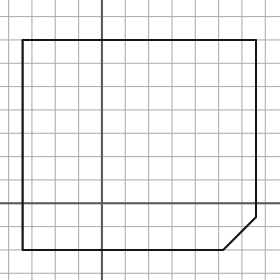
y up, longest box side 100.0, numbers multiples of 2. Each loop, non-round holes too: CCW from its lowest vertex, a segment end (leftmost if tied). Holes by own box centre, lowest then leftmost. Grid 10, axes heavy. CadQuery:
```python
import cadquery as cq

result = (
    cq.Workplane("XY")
    .moveTo(-34.0, -20.0)
    .lineTo(52.0, -20.0)
    .lineTo(66.0, -6.0)
    .lineTo(66.0, 70.0)
    .lineTo(-34.0, 70.0)
    .close()
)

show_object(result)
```